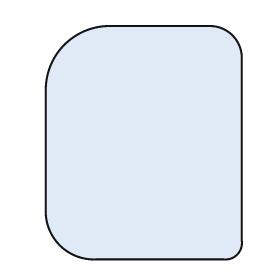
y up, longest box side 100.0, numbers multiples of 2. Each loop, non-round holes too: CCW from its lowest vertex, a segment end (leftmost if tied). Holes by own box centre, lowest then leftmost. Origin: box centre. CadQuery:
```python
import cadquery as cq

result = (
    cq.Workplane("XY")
    .moveTo(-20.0, -50.0)
    .lineTo(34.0, -50.0)
    .threePointArc((40.0, -48.0), (42.0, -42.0))
    .lineTo(42.0, 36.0)
    .threePointArc((38.0, 46.0), (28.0, 50.0))
    .lineTo(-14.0, 50.0)
    .threePointArc((-34.0, 42.0), (-42.0, 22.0))
    .lineTo(-42.0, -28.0)
    .threePointArc((-36.0, -44.0), (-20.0, -50.0))
    .close()
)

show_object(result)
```